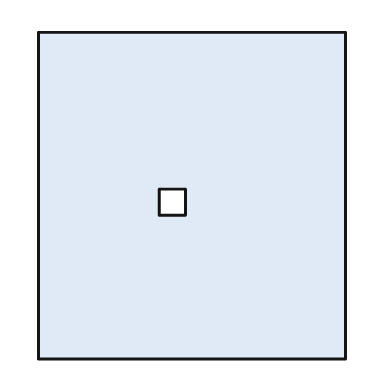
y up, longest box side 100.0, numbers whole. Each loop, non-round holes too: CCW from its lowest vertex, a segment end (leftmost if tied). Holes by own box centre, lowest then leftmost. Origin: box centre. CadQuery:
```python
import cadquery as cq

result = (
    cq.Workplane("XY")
    .moveTo(-47.0, -50.0)
    .lineTo(47.0, -50.0)
    .lineTo(47.0, 50.0)
    .lineTo(-47.0, 50.0)
    .close()
    .moveTo(-10.0, -6.0)
    .lineTo(-2.0, -6.0)
    .lineTo(-2.0, 2.0)
    .lineTo(-10.0, 2.0)
    .close()
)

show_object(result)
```